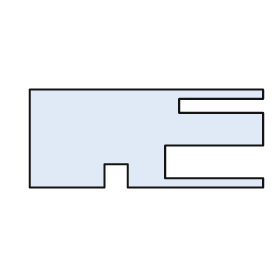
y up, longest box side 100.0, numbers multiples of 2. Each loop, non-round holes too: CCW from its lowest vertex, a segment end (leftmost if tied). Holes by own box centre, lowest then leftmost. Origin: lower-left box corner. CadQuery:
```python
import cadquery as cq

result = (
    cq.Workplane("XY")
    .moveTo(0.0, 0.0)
    .lineTo(32.0, 0.0)
    .lineTo(32.0, 10.0)
    .lineTo(42.0, 10.0)
    .lineTo(42.0, 0.0)
    .lineTo(100.0, 0.0)
    .lineTo(100.0, 4.0)
    .lineTo(58.0, 4.0)
    .lineTo(58.0, 18.0)
    .lineTo(100.0, 18.0)
    .lineTo(100.0, 32.0)
    .lineTo(64.0, 32.0)
    .lineTo(64.0, 38.0)
    .lineTo(100.0, 38.0)
    .lineTo(100.0, 42.0)
    .lineTo(0.0, 42.0)
    .close()
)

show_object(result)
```